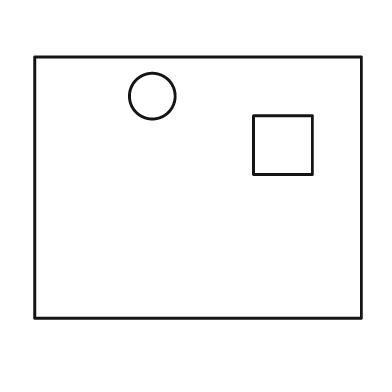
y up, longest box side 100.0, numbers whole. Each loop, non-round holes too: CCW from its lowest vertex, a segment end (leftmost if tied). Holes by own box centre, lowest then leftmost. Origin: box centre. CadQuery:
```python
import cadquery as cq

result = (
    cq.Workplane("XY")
    .moveTo(-50.0, -40.0)
    .lineTo(50.0, -40.0)
    .lineTo(50.0, 40.0)
    .lineTo(-50.0, 40.0)
    .close()
    .moveTo(17.0, 4.0)
    .lineTo(35.0, 4.0)
    .lineTo(35.0, 22.0)
    .lineTo(17.0, 22.0)
    .close()
    .moveTo(-14.0, 28.0)
    .circle(7.0)
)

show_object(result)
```